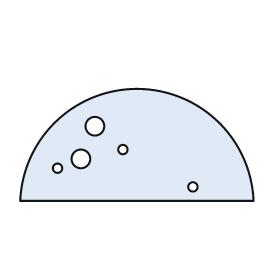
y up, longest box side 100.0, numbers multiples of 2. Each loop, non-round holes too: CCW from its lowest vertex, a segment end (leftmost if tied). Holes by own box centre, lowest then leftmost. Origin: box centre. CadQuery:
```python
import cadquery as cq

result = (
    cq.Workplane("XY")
    .moveTo(-50.0, -24.0)
    .lineTo(50.0, -24.0)
    .threePointArc((0.0, 24.0), (-50.0, -24.0))
    .close()
    .moveTo(24.0, -18.0)
    .circle(2.0)
    .moveTo(-34.0, -10.0)
    .circle(2.0)
    .moveTo(-24.0, -6.0)
    .circle(4.0)
    .moveTo(-6.0, -2.0)
    .circle(2.0)
    .moveTo(-18.0, 8.0)
    .circle(4.0)
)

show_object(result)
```